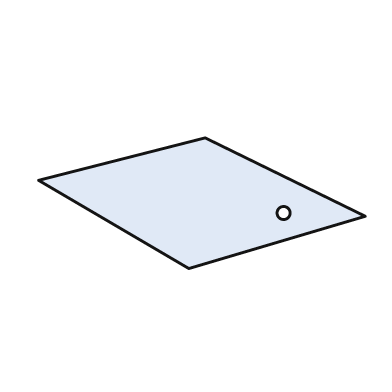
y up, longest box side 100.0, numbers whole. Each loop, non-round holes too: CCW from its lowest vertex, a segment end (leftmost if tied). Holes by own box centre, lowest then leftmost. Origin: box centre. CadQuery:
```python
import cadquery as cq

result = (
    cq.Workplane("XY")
    .moveTo(-4.0, -20.0)
    .lineTo(50.0, -4.0)
    .lineTo(1.0, 20.0)
    .lineTo(-50.0, 7.0)
    .close()
    .moveTo(25.0, -3.0)
    .circle(2.0)
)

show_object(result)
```